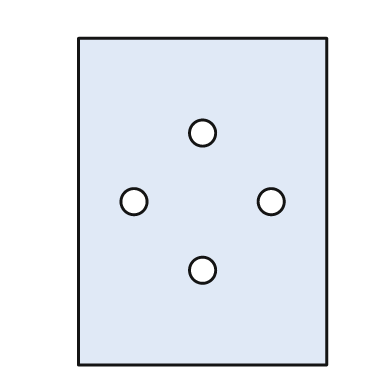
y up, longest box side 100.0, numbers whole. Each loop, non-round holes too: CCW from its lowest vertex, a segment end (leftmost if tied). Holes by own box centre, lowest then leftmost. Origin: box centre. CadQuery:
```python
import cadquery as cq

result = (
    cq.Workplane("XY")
    .moveTo(-38.0, -50.0)
    .lineTo(38.0, -50.0)
    .lineTo(38.0, 50.0)
    .lineTo(-38.0, 50.0)
    .close()
    .moveTo(0.0, -21.0)
    .circle(4.0)
    .moveTo(-21.0, 0.0)
    .circle(4.0)
    .moveTo(21.0, 0.0)
    .circle(4.0)
    .moveTo(0.0, 21.0)
    .circle(4.0)
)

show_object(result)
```